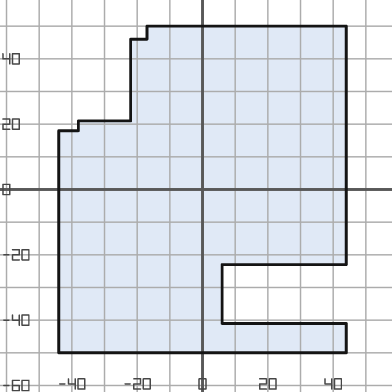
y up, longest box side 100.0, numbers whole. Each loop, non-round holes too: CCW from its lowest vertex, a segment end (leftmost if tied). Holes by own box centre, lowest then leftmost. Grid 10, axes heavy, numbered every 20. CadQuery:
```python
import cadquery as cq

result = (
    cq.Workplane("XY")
    .moveTo(-44.0, -50.0)
    .lineTo(44.0, -50.0)
    .lineTo(44.0, -41.0)
    .lineTo(6.0, -41.0)
    .lineTo(6.0, -23.0)
    .lineTo(44.0, -23.0)
    .lineTo(44.0, 50.0)
    .lineTo(-17.0, 50.0)
    .lineTo(-17.0, 46.0)
    .lineTo(-22.0, 46.0)
    .lineTo(-22.0, 21.0)
    .lineTo(-38.0, 21.0)
    .lineTo(-38.0, 18.0)
    .lineTo(-44.0, 18.0)
    .close()
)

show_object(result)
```